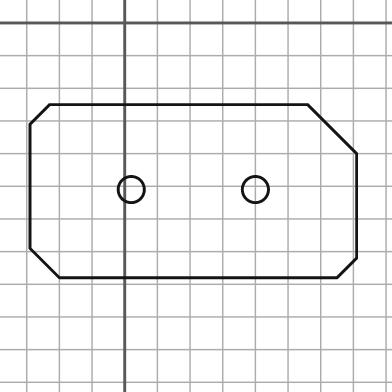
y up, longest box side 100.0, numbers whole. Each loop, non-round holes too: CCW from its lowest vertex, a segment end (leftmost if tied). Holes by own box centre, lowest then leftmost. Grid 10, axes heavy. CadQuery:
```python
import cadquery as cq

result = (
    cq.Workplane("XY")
    .moveTo(-20.0, -78.0)
    .lineTo(65.0, -78.0)
    .lineTo(71.0, -72.0)
    .lineTo(71.0, -40.0)
    .lineTo(56.0, -25.0)
    .lineTo(-23.0, -25.0)
    .lineTo(-29.0, -31.0)
    .lineTo(-29.0, -69.0)
    .close()
    .moveTo(2.0, -51.0)
    .circle(4.0)
    .moveTo(40.0, -51.0)
    .circle(4.0)
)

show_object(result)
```